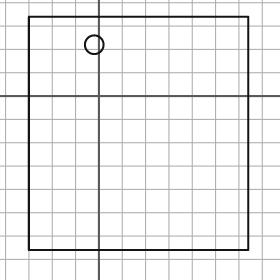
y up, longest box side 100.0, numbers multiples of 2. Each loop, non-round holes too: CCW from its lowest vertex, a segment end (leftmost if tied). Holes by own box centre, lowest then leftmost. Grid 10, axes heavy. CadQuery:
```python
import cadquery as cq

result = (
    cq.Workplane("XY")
    .moveTo(-30.0, -66.0)
    .lineTo(64.0, -66.0)
    .lineTo(64.0, 34.0)
    .lineTo(-30.0, 34.0)
    .close()
    .moveTo(-2.0, 22.0)
    .circle(4.0)
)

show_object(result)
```